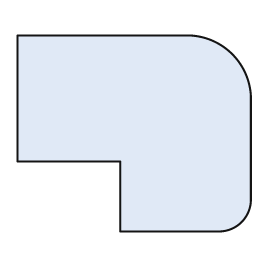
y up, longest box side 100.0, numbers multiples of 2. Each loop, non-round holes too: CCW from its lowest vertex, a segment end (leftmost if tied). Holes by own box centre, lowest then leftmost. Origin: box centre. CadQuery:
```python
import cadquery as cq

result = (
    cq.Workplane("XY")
    .moveTo(-6.0, -42.0)
    .lineTo(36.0, -42.0)
    .threePointArc((46.0, -38.0), (50.0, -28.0))
    .lineTo(50.0, 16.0)
    .threePointArc((42.0, 34.0), (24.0, 42.0))
    .lineTo(-50.0, 42.0)
    .lineTo(-50.0, -12.0)
    .lineTo(-6.0, -12.0)
    .close()
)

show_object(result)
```